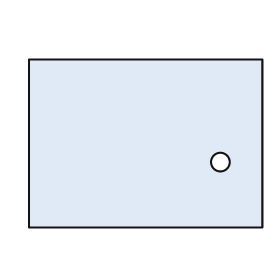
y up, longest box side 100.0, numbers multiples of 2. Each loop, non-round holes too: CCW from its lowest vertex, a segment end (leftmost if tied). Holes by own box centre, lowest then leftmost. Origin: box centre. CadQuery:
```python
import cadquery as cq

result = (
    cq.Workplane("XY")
    .moveTo(-50.0, -36.0)
    .lineTo(50.0, -36.0)
    .lineTo(50.0, 36.0)
    .lineTo(-50.0, 36.0)
    .close()
    .moveTo(32.0, -8.0)
    .circle(4.0)
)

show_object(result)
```